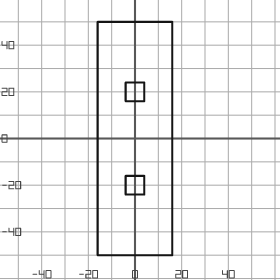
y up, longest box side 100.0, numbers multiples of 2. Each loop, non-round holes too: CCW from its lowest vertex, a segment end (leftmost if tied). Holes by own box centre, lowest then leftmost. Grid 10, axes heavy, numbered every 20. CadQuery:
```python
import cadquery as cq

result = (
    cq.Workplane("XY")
    .moveTo(-16.0, -50.0)
    .lineTo(16.0, -50.0)
    .lineTo(16.0, 50.0)
    .lineTo(-16.0, 50.0)
    .close()
    .moveTo(-4.0, -24.0)
    .lineTo(4.0, -24.0)
    .lineTo(4.0, -16.0)
    .lineTo(-4.0, -16.0)
    .close()
    .moveTo(-4.0, 16.0)
    .lineTo(4.0, 16.0)
    .lineTo(4.0, 24.0)
    .lineTo(-4.0, 24.0)
    .close()
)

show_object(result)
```